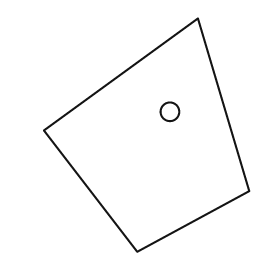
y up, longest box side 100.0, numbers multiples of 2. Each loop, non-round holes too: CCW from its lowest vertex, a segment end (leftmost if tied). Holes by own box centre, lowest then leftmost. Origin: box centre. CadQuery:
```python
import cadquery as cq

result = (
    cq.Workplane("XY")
    .moveTo(-4.0, -50.0)
    .lineTo(44.0, -24.0)
    .lineTo(22.0, 50.0)
    .lineTo(-44.0, 2.0)
    .close()
    .moveTo(10.0, 10.0)
    .circle(4.0)
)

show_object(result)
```